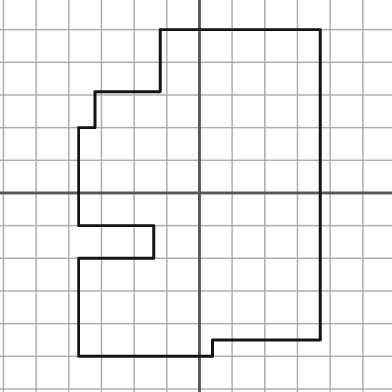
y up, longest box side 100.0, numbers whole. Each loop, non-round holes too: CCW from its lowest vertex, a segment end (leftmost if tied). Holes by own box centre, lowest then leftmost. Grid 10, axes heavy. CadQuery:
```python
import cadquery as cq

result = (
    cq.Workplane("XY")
    .moveTo(-37.0, -50.0)
    .lineTo(4.0, -50.0)
    .lineTo(4.0, -45.0)
    .lineTo(37.0, -45.0)
    .lineTo(37.0, 50.0)
    .lineTo(-12.0, 50.0)
    .lineTo(-12.0, 31.0)
    .lineTo(-32.0, 31.0)
    .lineTo(-32.0, 20.0)
    .lineTo(-37.0, 20.0)
    .lineTo(-37.0, -10.0)
    .lineTo(-14.0, -10.0)
    .lineTo(-14.0, -20.0)
    .lineTo(-37.0, -20.0)
    .close()
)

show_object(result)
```